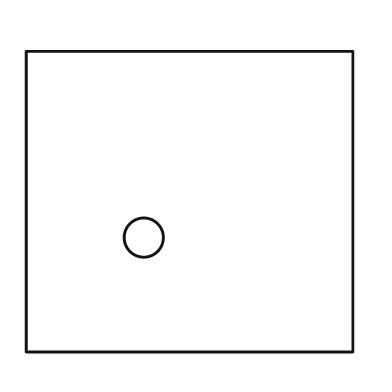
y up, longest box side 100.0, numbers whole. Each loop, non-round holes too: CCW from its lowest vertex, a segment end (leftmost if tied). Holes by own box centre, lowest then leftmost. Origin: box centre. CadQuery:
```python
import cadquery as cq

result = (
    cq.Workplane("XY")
    .moveTo(-50.0, -46.0)
    .lineTo(50.0, -46.0)
    .lineTo(50.0, 46.0)
    .lineTo(-50.0, 46.0)
    .close()
    .moveTo(-14.0, -11.0)
    .circle(6.0)
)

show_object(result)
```